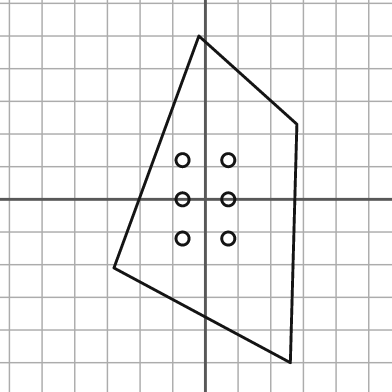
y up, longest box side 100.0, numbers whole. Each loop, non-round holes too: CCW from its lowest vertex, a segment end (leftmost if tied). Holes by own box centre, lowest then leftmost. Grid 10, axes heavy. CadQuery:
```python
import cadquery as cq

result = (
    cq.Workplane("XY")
    .moveTo(26.0, -50.0)
    .lineTo(28.0, 23.0)
    .lineTo(-2.0, 50.0)
    .lineTo(-28.0, -21.0)
    .close()
    .moveTo(-7.0, -12.0)
    .circle(2.0)
    .moveTo(7.0, -12.0)
    .circle(2.0)
    .moveTo(-7.0, 0.0)
    .circle(2.0)
    .moveTo(7.0, 0.0)
    .circle(2.0)
    .moveTo(-7.0, 12.0)
    .circle(2.0)
    .moveTo(7.0, 12.0)
    .circle(2.0)
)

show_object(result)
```